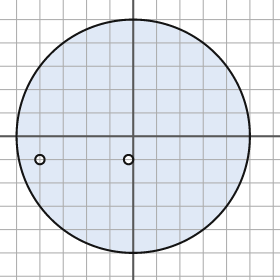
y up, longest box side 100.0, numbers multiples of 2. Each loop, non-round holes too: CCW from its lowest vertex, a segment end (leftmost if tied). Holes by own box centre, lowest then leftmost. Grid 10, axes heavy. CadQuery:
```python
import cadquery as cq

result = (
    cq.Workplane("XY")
    .moveTo(0.0, 0.0)
    .circle(50.0)
    .moveTo(-40.0, -10.0)
    .circle(2.0)
    .moveTo(-2.0, -10.0)
    .circle(2.0)
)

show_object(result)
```